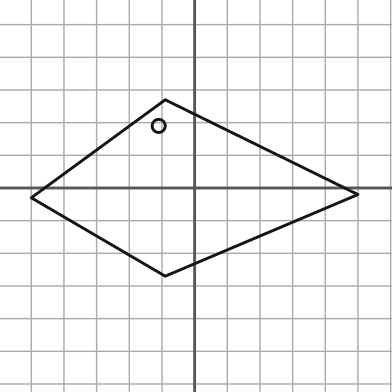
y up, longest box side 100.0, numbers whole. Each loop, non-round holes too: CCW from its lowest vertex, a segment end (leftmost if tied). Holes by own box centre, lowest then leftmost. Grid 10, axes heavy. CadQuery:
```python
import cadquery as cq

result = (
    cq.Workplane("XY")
    .moveTo(-9.0, -27.0)
    .lineTo(50.0, -2.0)
    .lineTo(-9.0, 27.0)
    .lineTo(-50.0, -3.0)
    .close()
    .moveTo(-11.0, 19.0)
    .circle(2.0)
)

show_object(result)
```